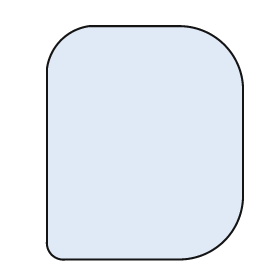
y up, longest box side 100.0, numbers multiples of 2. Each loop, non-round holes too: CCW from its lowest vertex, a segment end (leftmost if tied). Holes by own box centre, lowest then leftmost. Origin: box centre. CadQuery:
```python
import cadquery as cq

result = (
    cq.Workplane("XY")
    .moveTo(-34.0, -50.0)
    .lineTo(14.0, -50.0)
    .threePointArc((34.0, -42.0), (42.0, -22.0))
    .lineTo(42.0, 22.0)
    .threePointArc((34.0, 42.0), (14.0, 50.0))
    .lineTo(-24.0, 50.0)
    .threePointArc((-36.0, 44.0), (-42.0, 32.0))
    .lineTo(-42.0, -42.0)
    .threePointArc((-40.0, -48.0), (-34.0, -50.0))
    .close()
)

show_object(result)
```